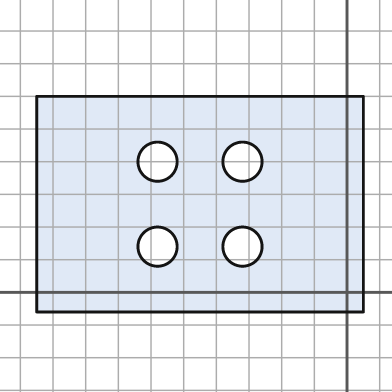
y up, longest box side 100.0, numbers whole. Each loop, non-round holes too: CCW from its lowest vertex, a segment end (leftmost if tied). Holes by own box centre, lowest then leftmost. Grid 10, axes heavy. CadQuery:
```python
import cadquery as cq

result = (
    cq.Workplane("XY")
    .moveTo(-95.0, -6.0)
    .lineTo(5.0, -6.0)
    .lineTo(5.0, 60.0)
    .lineTo(-95.0, 60.0)
    .close()
    .moveTo(-58.0, 14.0)
    .circle(6.0)
    .moveTo(-32.0, 14.0)
    .circle(6.0)
    .moveTo(-58.0, 40.0)
    .circle(6.0)
    .moveTo(-32.0, 40.0)
    .circle(6.0)
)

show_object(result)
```